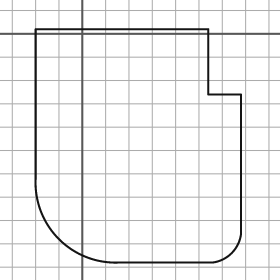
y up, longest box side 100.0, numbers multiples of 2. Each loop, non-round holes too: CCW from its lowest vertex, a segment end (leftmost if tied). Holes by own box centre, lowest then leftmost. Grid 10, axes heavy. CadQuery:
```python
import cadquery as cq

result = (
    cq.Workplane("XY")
    .moveTo(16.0, -98.0)
    .lineTo(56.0, -98.0)
    .threePointArc((64.0, -94.0), (68.0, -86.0))
    .lineTo(68.0, -26.0)
    .lineTo(54.0, -26.0)
    .lineTo(54.0, 2.0)
    .lineTo(-20.0, 2.0)
    .lineTo(-20.0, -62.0)
    .threePointArc((-10.0, -88.0), (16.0, -98.0))
    .close()
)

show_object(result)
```